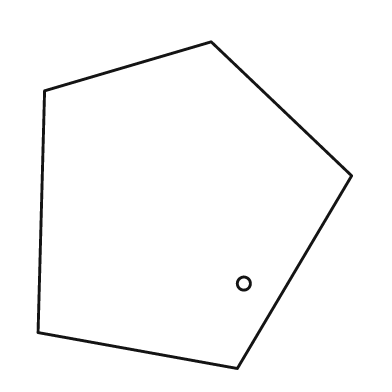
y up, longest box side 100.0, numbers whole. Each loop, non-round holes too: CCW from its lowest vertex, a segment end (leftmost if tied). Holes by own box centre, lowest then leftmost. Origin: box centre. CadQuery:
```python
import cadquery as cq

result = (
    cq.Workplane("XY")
    .moveTo(13.0, -50.0)
    .lineTo(48.0, 9.0)
    .lineTo(5.0, 50.0)
    .lineTo(-46.0, 35.0)
    .lineTo(-48.0, -39.0)
    .close()
    .moveTo(15.0, -24.0)
    .circle(2.0)
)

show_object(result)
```